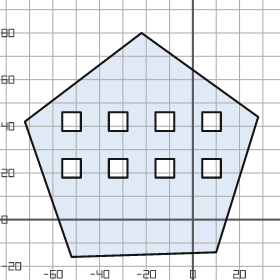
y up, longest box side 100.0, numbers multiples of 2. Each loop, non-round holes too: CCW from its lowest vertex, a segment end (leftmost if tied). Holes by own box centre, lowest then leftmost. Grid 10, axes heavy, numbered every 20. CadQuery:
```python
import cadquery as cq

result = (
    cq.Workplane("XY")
    .moveTo(-52.0, -16.0)
    .lineTo(10.0, -14.0)
    .lineTo(28.0, 44.0)
    .lineTo(-22.0, 80.0)
    .lineTo(-72.0, 42.0)
    .close()
    .moveTo(-56.0, 18.0)
    .lineTo(-48.0, 18.0)
    .lineTo(-48.0, 26.0)
    .lineTo(-56.0, 26.0)
    .close()
    .moveTo(-36.0, 18.0)
    .lineTo(-28.0, 18.0)
    .lineTo(-28.0, 26.0)
    .lineTo(-36.0, 26.0)
    .close()
    .moveTo(-16.0, 18.0)
    .lineTo(-8.0, 18.0)
    .lineTo(-8.0, 26.0)
    .lineTo(-16.0, 26.0)
    .close()
    .moveTo(4.0, 18.0)
    .lineTo(12.0, 18.0)
    .lineTo(12.0, 26.0)
    .lineTo(4.0, 26.0)
    .close()
    .moveTo(-56.0, 38.0)
    .lineTo(-48.0, 38.0)
    .lineTo(-48.0, 46.0)
    .lineTo(-56.0, 46.0)
    .close()
    .moveTo(-36.0, 38.0)
    .lineTo(-28.0, 38.0)
    .lineTo(-28.0, 46.0)
    .lineTo(-36.0, 46.0)
    .close()
    .moveTo(-16.0, 38.0)
    .lineTo(-8.0, 38.0)
    .lineTo(-8.0, 46.0)
    .lineTo(-16.0, 46.0)
    .close()
    .moveTo(4.0, 38.0)
    .lineTo(12.0, 38.0)
    .lineTo(12.0, 46.0)
    .lineTo(4.0, 46.0)
    .close()
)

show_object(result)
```